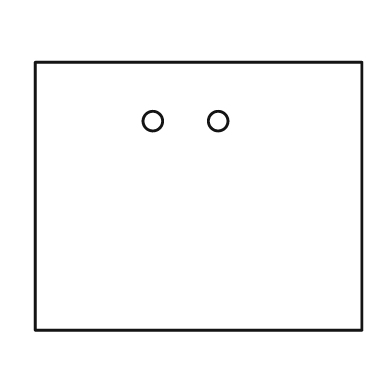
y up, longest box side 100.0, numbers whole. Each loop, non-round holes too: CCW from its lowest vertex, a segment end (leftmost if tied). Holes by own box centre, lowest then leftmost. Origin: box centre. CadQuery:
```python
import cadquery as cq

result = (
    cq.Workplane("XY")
    .moveTo(-50.0, -41.0)
    .lineTo(50.0, -41.0)
    .lineTo(50.0, 41.0)
    .lineTo(-50.0, 41.0)
    .close()
    .moveTo(-14.0, 23.0)
    .circle(3.0)
    .moveTo(6.0, 23.0)
    .circle(3.0)
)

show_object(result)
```